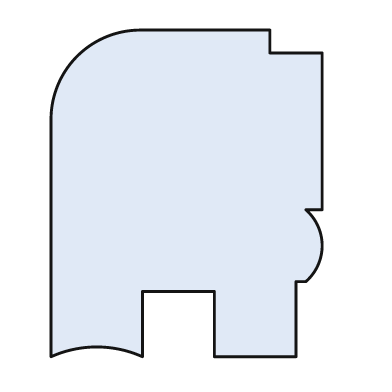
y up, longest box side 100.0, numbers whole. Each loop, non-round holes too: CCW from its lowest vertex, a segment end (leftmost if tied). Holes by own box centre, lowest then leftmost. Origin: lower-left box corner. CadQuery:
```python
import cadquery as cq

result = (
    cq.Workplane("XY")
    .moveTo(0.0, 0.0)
    .threePointArc((14.0, 3.0), (28.0, 0.0))
    .lineTo(28.0, 20.0)
    .lineTo(50.0, 20.0)
    .lineTo(50.0, 0.0)
    .lineTo(75.0, 0.0)
    .lineTo(75.0, 23.0)
    .lineTo(78.0, 23.0)
    .threePointArc((83.0, 34.0), (78.0, 45.0))
    .lineTo(83.0, 45.0)
    .lineTo(83.0, 93.0)
    .lineTo(67.0, 93.0)
    .lineTo(67.0, 100.0)
    .lineTo(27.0, 100.0)
    .threePointArc((8.0, 92.0), (0.0, 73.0))
    .close()
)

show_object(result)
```